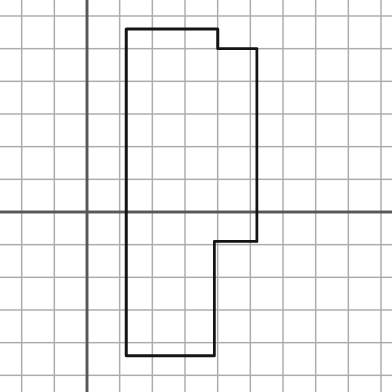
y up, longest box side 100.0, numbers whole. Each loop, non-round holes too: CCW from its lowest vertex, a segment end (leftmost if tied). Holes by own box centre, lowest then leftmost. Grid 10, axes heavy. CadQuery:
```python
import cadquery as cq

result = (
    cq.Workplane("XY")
    .moveTo(12.0, -44.0)
    .lineTo(39.0, -44.0)
    .lineTo(39.0, -9.0)
    .lineTo(52.0, -9.0)
    .lineTo(52.0, 50.0)
    .lineTo(40.0, 50.0)
    .lineTo(40.0, 56.0)
    .lineTo(12.0, 56.0)
    .close()
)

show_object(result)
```